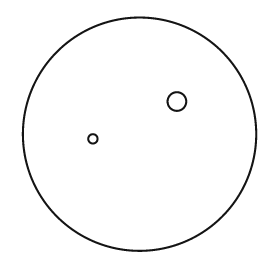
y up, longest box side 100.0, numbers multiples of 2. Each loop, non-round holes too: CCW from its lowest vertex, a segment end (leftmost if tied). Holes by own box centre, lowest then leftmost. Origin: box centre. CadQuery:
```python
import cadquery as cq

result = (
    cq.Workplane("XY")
    .moveTo(0.0, 0.0)
    .circle(50.0)
    .moveTo(-20.0, -2.0)
    .circle(2.0)
    .moveTo(16.0, 14.0)
    .circle(4.0)
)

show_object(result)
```